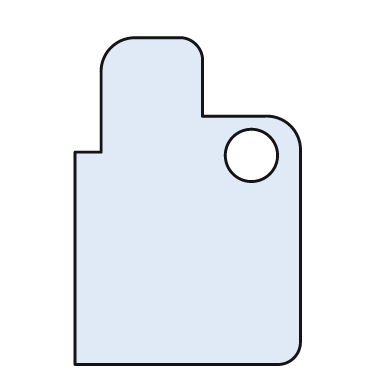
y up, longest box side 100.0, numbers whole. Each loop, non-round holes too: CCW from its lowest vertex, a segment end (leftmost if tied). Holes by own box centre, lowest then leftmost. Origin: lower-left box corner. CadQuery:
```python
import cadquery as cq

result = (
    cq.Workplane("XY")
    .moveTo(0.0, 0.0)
    .lineTo(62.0, 0.0)
    .threePointArc((67.0, 2.0), (69.0, 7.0))
    .lineTo(69.0, 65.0)
    .threePointArc((66.0, 73.0), (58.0, 76.0))
    .lineTo(39.0, 76.0)
    .lineTo(39.0, 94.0)
    .threePointArc((37.0, 98.0), (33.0, 100.0))
    .lineTo(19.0, 100.0)
    .threePointArc((11.0, 97.0), (8.0, 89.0))
    .lineTo(8.0, 65.0)
    .lineTo(0.0, 65.0)
    .close()
    .moveTo(54.0, 64.0)
    .circle(8.0)
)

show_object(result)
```